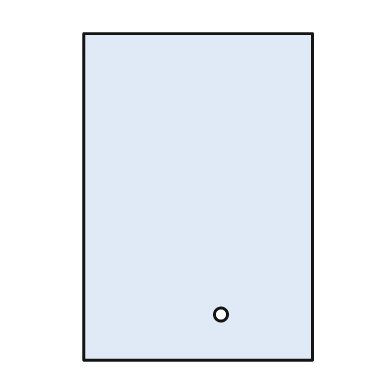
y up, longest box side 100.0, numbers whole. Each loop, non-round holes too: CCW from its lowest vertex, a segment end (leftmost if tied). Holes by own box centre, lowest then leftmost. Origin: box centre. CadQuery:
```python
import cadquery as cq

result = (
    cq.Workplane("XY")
    .moveTo(-35.0, -50.0)
    .lineTo(35.0, -50.0)
    .lineTo(35.0, 50.0)
    .lineTo(-35.0, 50.0)
    .close()
    .moveTo(7.0, -36.0)
    .circle(2.0)
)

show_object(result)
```